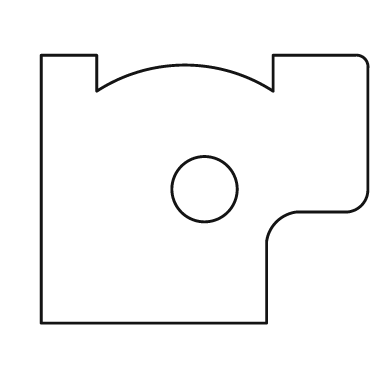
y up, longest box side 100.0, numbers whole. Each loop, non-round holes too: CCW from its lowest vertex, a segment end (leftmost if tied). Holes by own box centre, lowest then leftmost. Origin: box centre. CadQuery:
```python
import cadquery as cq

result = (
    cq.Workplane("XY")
    .moveTo(-50.0, -41.0)
    .lineTo(19.0, -41.0)
    .lineTo(19.0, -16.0)
    .threePointArc((22.0, -10.0), (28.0, -7.0))
    .lineTo(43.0, -7.0)
    .threePointArc((48.0, -5.0), (50.0, 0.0))
    .lineTo(50.0, 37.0)
    .threePointArc((49.0, 40.0), (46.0, 41.0))
    .lineTo(21.0, 41.0)
    .lineTo(21.0, 30.0)
    .threePointArc((-6.0, 38.0), (-33.0, 30.0))
    .lineTo(-33.0, 41.0)
    .lineTo(-50.0, 41.0)
    .close()
    .moveTo(0.0, 0.0)
    .circle(10.0)
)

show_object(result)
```